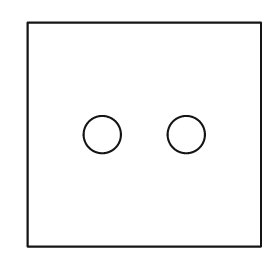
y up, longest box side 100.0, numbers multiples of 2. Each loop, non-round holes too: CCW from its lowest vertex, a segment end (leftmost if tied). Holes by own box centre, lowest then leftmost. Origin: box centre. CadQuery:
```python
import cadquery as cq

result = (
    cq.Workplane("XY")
    .moveTo(-50.0, -48.0)
    .lineTo(50.0, -48.0)
    .lineTo(50.0, 48.0)
    .lineTo(-50.0, 48.0)
    .close()
    .moveTo(-18.0, 0.0)
    .circle(8.0)
    .moveTo(18.0, 0.0)
    .circle(8.0)
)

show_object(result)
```